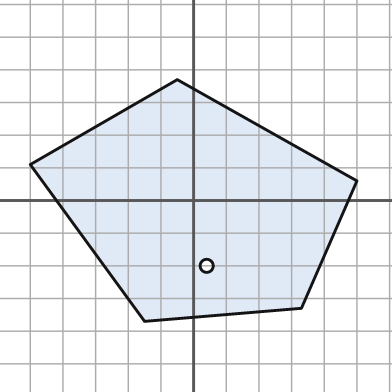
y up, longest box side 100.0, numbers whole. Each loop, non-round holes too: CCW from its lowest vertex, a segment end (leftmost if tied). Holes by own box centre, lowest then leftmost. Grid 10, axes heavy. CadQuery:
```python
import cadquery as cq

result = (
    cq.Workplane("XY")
    .moveTo(-15.0, -37.0)
    .lineTo(33.0, -33.0)
    .lineTo(50.0, 6.0)
    .lineTo(-5.0, 37.0)
    .lineTo(-50.0, 11.0)
    .close()
    .moveTo(4.0, -20.0)
    .circle(2.0)
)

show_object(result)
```